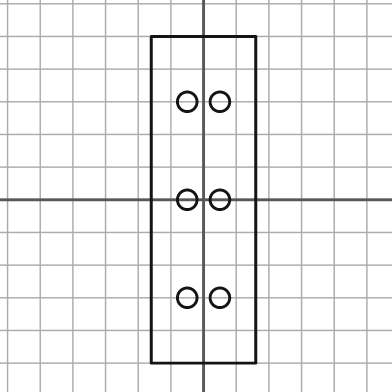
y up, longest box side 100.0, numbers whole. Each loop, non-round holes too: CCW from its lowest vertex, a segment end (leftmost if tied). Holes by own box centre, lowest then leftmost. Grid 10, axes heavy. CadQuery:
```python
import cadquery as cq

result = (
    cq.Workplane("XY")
    .moveTo(-16.0, -50.0)
    .lineTo(16.0, -50.0)
    .lineTo(16.0, 50.0)
    .lineTo(-16.0, 50.0)
    .close()
    .moveTo(-5.0, -30.0)
    .circle(3.0)
    .moveTo(5.0, -30.0)
    .circle(3.0)
    .moveTo(-5.0, 0.0)
    .circle(3.0)
    .moveTo(5.0, 0.0)
    .circle(3.0)
    .moveTo(-5.0, 30.0)
    .circle(3.0)
    .moveTo(5.0, 30.0)
    .circle(3.0)
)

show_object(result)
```